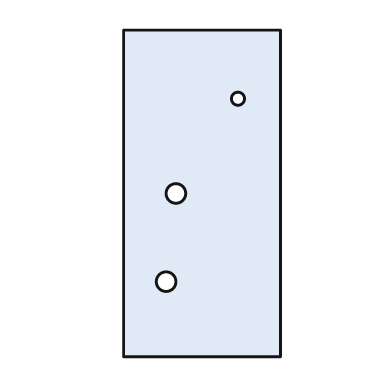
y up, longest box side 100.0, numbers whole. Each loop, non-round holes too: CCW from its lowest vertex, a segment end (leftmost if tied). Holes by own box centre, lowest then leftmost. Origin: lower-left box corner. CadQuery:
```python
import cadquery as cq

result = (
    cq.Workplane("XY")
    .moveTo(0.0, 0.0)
    .lineTo(48.0, 0.0)
    .lineTo(48.0, 100.0)
    .lineTo(0.0, 100.0)
    .close()
    .moveTo(13.0, 23.0)
    .circle(3.0)
    .moveTo(16.0, 50.0)
    .circle(3.0)
    .moveTo(35.0, 79.0)
    .circle(2.0)
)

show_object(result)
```